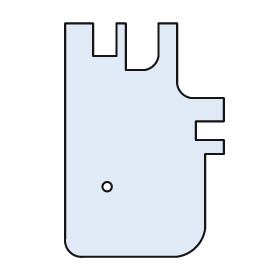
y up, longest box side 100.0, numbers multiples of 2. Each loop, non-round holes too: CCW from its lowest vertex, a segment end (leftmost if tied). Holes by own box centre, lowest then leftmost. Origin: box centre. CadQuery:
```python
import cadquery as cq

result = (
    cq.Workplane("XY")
    .moveTo(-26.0, -50.0)
    .lineTo(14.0, -50.0)
    .threePointArc((22.0, -46.0), (26.0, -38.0))
    .lineTo(26.0, -6.0)
    .lineTo(34.0, -6.0)
    .lineTo(34.0, 0.0)
    .lineTo(22.0, 0.0)
    .lineTo(22.0, 8.0)
    .lineTo(34.0, 8.0)
    .lineTo(34.0, 18.0)
    .lineTo(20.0, 18.0)
    .threePointArc((16.0, 20.0), (14.0, 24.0))
    .lineTo(14.0, 50.0)
    .lineTo(6.0, 50.0)
    .lineTo(6.0, 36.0)
    .threePointArc((4.0, 32.0), (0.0, 30.0))
    .lineTo(-8.0, 30.0)
    .lineTo(-8.0, 50.0)
    .lineTo(-12.0, 50.0)
    .lineTo(-12.0, 36.0)
    .lineTo(-22.0, 36.0)
    .lineTo(-22.0, 50.0)
    .lineTo(-34.0, 50.0)
    .lineTo(-34.0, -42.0)
    .threePointArc((-32.0, -48.0), (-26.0, -50.0))
    .close()
    .moveTo(-16.0, -20.0)
    .circle(2.0)
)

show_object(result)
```